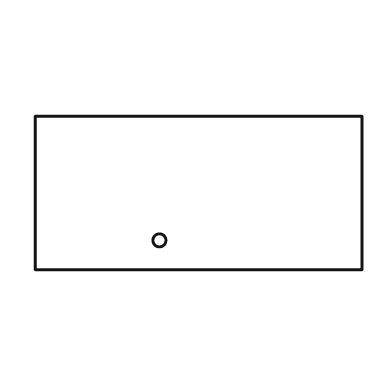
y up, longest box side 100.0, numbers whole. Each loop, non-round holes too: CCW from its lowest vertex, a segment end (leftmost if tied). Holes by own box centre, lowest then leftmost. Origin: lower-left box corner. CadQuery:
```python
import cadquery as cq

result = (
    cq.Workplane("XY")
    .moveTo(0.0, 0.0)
    .lineTo(100.0, 0.0)
    .lineTo(100.0, 47.0)
    .lineTo(0.0, 47.0)
    .close()
    .moveTo(38.0, 9.0)
    .circle(2.0)
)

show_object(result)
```